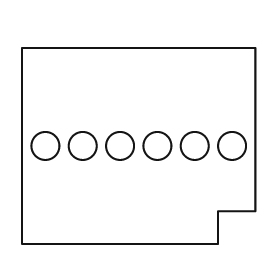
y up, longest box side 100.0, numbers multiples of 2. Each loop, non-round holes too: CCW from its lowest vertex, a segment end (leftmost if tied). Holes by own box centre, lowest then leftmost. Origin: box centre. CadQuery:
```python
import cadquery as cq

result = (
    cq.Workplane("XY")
    .moveTo(-50.0, -42.0)
    .lineTo(34.0, -42.0)
    .lineTo(34.0, -28.0)
    .lineTo(50.0, -28.0)
    .lineTo(50.0, 42.0)
    .lineTo(-50.0, 42.0)
    .close()
    .moveTo(-40.0, 0.0)
    .circle(6.0)
    .moveTo(-24.0, 0.0)
    .circle(6.0)
    .moveTo(-8.0, 0.0)
    .circle(6.0)
    .moveTo(8.0, 0.0)
    .circle(6.0)
    .moveTo(24.0, 0.0)
    .circle(6.0)
    .moveTo(40.0, 0.0)
    .circle(6.0)
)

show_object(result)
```